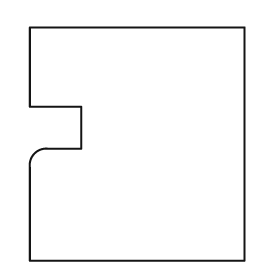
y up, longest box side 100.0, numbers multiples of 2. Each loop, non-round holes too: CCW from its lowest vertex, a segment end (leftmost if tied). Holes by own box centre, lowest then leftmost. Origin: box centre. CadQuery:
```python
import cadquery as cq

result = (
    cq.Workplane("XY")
    .moveTo(-46.0, -50.0)
    .lineTo(46.0, -50.0)
    .lineTo(46.0, 50.0)
    .lineTo(-46.0, 50.0)
    .lineTo(-46.0, 16.0)
    .lineTo(-24.0, 16.0)
    .lineTo(-24.0, -2.0)
    .lineTo(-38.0, -2.0)
    .threePointArc((-44.0, -4.0), (-46.0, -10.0))
    .close()
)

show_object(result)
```